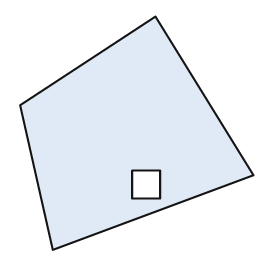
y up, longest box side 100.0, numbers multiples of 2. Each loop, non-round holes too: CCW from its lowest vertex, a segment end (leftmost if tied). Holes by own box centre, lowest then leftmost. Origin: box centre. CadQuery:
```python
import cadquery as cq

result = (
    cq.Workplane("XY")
    .moveTo(-36.0, -50.0)
    .lineTo(50.0, -18.0)
    .lineTo(8.0, 50.0)
    .lineTo(-50.0, 12.0)
    .close()
    .moveTo(-2.0, -28.0)
    .lineTo(10.0, -28.0)
    .lineTo(10.0, -16.0)
    .lineTo(-2.0, -16.0)
    .close()
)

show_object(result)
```